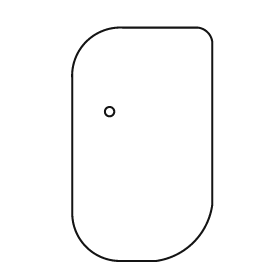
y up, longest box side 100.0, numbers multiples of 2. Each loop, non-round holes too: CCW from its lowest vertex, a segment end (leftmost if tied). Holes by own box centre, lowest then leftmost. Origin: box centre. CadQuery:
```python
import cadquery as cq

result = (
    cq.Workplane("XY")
    .moveTo(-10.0, -50.0)
    .lineTo(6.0, -50.0)
    .threePointArc((22.0, -42.0), (30.0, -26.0))
    .lineTo(30.0, 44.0)
    .threePointArc((28.0, 48.0), (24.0, 50.0))
    .lineTo(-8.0, 50.0)
    .threePointArc((-24.0, 44.0), (-30.0, 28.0))
    .lineTo(-30.0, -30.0)
    .threePointArc((-24.0, -44.0), (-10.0, -50.0))
    .close()
    .moveTo(-14.0, 14.0)
    .circle(2.0)
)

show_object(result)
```